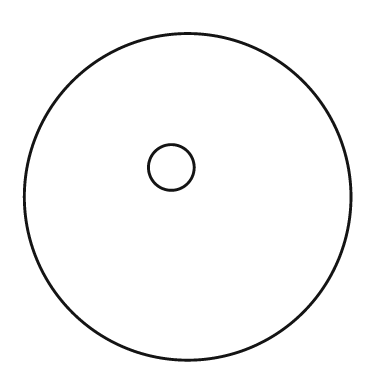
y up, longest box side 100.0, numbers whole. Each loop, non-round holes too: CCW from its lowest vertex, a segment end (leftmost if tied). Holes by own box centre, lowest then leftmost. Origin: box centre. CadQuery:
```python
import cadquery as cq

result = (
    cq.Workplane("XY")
    .moveTo(0.0, 0.0)
    .circle(50.0)
    .moveTo(-5.0, 9.0)
    .circle(7.0)
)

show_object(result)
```